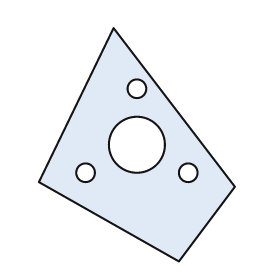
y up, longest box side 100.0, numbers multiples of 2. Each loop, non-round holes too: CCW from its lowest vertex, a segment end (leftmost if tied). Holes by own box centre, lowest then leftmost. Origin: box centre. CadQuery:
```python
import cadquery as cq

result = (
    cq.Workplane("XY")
    .moveTo(18.0, -50.0)
    .lineTo(42.0, -18.0)
    .lineTo(-10.0, 50.0)
    .lineTo(-42.0, -16.0)
    .close()
    .moveTo(-22.0, -12.0)
    .circle(4.0)
    .moveTo(22.0, -12.0)
    .circle(4.0)
    .moveTo(0.0, 0.0)
    .circle(12.0)
    .moveTo(0.0, 24.0)
    .circle(4.0)
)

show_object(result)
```